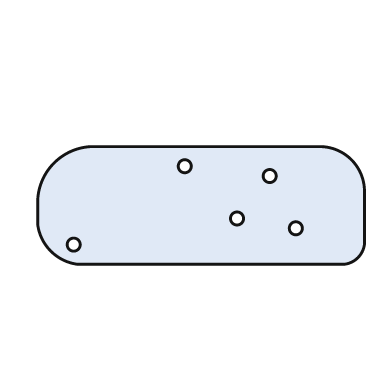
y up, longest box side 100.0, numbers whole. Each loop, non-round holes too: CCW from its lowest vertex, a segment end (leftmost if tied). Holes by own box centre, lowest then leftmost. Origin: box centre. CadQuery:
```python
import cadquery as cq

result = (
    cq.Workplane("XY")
    .moveTo(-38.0, -18.0)
    .lineTo(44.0, -18.0)
    .threePointArc((48.0, -16.0), (50.0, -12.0))
    .lineTo(50.0, 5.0)
    .threePointArc((46.0, 14.0), (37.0, 18.0))
    .lineTo(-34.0, 18.0)
    .threePointArc((-45.0, 13.0), (-50.0, 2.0))
    .lineTo(-50.0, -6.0)
    .threePointArc((-46.0, -14.0), (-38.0, -18.0))
    .close()
    .moveTo(-39.0, -12.0)
    .circle(2.0)
    .moveTo(29.0, -7.0)
    .circle(2.0)
    .moveTo(11.0, -4.0)
    .circle(2.0)
    .moveTo(21.0, 9.0)
    .circle(2.0)
    .moveTo(-5.0, 12.0)
    .circle(2.0)
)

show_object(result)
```